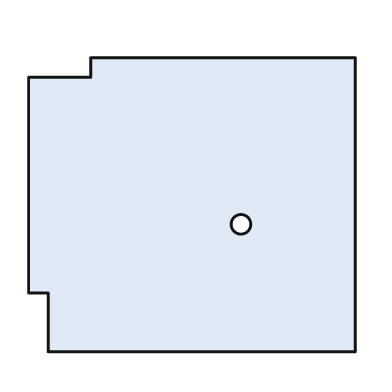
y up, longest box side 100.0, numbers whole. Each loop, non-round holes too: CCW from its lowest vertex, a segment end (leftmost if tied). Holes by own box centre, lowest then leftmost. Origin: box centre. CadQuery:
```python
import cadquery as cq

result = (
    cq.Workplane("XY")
    .moveTo(-44.0, -45.0)
    .lineTo(50.0, -45.0)
    .lineTo(50.0, 45.0)
    .lineTo(-31.0, 45.0)
    .lineTo(-31.0, 39.0)
    .lineTo(-50.0, 39.0)
    .lineTo(-50.0, -27.0)
    .lineTo(-44.0, -27.0)
    .close()
    .moveTo(15.0, -6.0)
    .circle(3.0)
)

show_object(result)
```